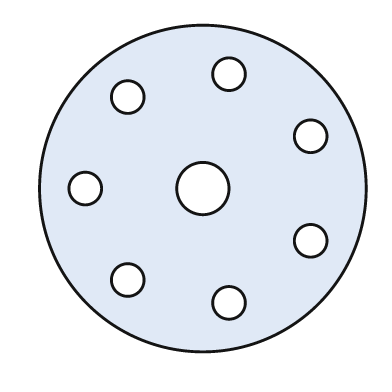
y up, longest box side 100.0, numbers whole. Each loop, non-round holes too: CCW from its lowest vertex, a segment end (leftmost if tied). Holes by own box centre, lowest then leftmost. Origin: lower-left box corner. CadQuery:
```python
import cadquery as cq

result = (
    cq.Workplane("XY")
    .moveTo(50.0, 50.0)
    .circle(50.0)
    .moveTo(58.0, 15.0)
    .circle(5.0)
    .moveTo(27.0, 22.0)
    .circle(5.0)
    .moveTo(83.0, 34.0)
    .circle(5.0)
    .moveTo(14.0, 50.0)
    .circle(5.0)
    .moveTo(50.0, 50.0)
    .circle(8.0)
    .moveTo(83.0, 66.0)
    .circle(5.0)
    .moveTo(27.0, 78.0)
    .circle(5.0)
    .moveTo(58.0, 85.0)
    .circle(5.0)
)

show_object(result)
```